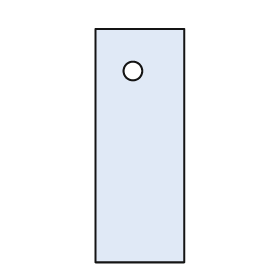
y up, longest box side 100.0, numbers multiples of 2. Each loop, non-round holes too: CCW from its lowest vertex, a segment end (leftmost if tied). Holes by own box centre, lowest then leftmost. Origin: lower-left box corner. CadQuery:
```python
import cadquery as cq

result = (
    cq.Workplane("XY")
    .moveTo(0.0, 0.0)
    .lineTo(38.0, 0.0)
    .lineTo(38.0, 100.0)
    .lineTo(0.0, 100.0)
    .close()
    .moveTo(16.0, 82.0)
    .circle(4.0)
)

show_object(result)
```